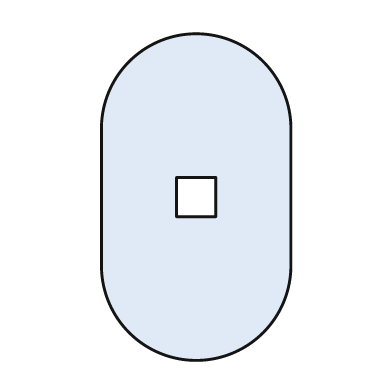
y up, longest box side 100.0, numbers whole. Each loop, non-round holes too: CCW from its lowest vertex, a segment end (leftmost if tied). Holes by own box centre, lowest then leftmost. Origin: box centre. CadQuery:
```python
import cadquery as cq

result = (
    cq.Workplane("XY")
    .moveTo(-29.0, -21.0)
    .threePointArc((0.0, -50.0), (29.0, -21.0))
    .lineTo(29.0, 21.0)
    .threePointArc((0.0, 50.0), (-29.0, 21.0))
    .close()
    .moveTo(-6.0, -6.0)
    .lineTo(6.0, -6.0)
    .lineTo(6.0, 6.0)
    .lineTo(-6.0, 6.0)
    .close()
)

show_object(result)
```